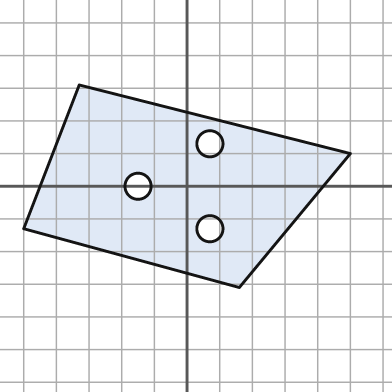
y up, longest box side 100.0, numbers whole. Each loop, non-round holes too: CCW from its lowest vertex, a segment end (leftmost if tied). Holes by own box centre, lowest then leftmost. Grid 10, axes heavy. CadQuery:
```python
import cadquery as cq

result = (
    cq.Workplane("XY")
    .moveTo(16.0, -31.0)
    .lineTo(50.0, 10.0)
    .lineTo(-33.0, 31.0)
    .lineTo(-50.0, -13.0)
    .close()
    .moveTo(7.0, -13.0)
    .circle(4.0)
    .moveTo(-15.0, 0.0)
    .circle(4.0)
    .moveTo(7.0, 13.0)
    .circle(4.0)
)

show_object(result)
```